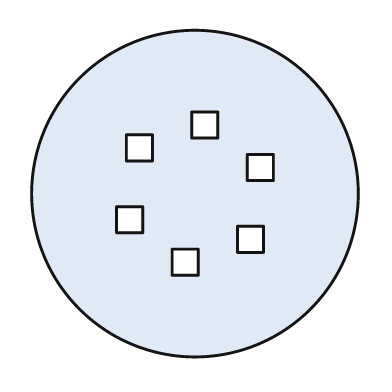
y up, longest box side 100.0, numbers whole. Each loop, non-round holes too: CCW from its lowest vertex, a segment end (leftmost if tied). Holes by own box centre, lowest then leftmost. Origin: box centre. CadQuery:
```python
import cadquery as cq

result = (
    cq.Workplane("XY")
    .moveTo(0.0, 0.0)
    .circle(50.0)
    .moveTo(-7.0, -25.0)
    .lineTo(1.0, -25.0)
    .lineTo(1.0, -17.0)
    .lineTo(-7.0, -17.0)
    .close()
    .moveTo(13.0, -18.0)
    .lineTo(21.0, -18.0)
    .lineTo(21.0, -10.0)
    .lineTo(13.0, -10.0)
    .close()
    .moveTo(-24.0, -12.0)
    .lineTo(-16.0, -12.0)
    .lineTo(-16.0, -4.0)
    .lineTo(-24.0, -4.0)
    .close()
    .moveTo(16.0, 4.0)
    .lineTo(24.0, 4.0)
    .lineTo(24.0, 12.0)
    .lineTo(16.0, 12.0)
    .close()
    .moveTo(-21.0, 10.0)
    .lineTo(-13.0, 10.0)
    .lineTo(-13.0, 18.0)
    .lineTo(-21.0, 18.0)
    .close()
    .moveTo(-1.0, 17.0)
    .lineTo(7.0, 17.0)
    .lineTo(7.0, 25.0)
    .lineTo(-1.0, 25.0)
    .close()
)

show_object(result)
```